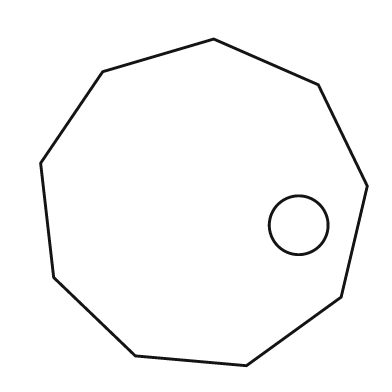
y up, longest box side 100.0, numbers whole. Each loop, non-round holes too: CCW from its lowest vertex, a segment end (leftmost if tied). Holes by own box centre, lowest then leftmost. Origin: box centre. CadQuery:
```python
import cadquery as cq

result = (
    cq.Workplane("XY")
    .moveTo(13.0, -50.0)
    .lineTo(42.0, -29.0)
    .lineTo(50.0, 5.0)
    .lineTo(35.0, 36.0)
    .lineTo(3.0, 50.0)
    .lineTo(-31.0, 40.0)
    .lineTo(-50.0, 12.0)
    .lineTo(-46.0, -23.0)
    .lineTo(-21.0, -47.0)
    .close()
    .moveTo(29.0, -7.0)
    .circle(9.0)
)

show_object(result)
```